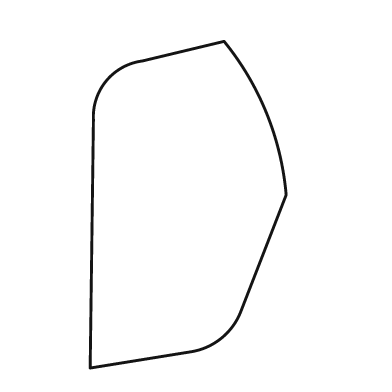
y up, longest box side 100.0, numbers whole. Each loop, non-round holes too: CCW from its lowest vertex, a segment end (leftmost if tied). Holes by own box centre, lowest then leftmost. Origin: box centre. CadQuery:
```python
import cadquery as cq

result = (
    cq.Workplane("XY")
    .moveTo(-30.0, -50.0)
    .lineTo(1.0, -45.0)
    .threePointArc((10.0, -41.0), (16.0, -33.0))
    .lineTo(30.0, 3.0)
    .threePointArc((24.0, 28.0), (11.0, 50.0))
    .lineTo(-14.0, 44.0)
    .threePointArc((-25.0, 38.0), (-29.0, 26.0))
    .close()
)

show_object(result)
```